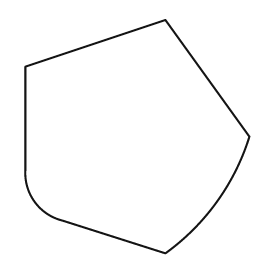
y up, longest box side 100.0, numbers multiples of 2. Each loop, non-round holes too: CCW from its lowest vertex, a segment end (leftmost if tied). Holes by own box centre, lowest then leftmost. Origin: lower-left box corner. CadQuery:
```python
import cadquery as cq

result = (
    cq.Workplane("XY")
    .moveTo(60.0, 0.0)
    .threePointArc((82.0, 22.0), (96.0, 50.0))
    .lineTo(60.0, 100.0)
    .lineTo(0.0, 80.0)
    .lineTo(0.0, 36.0)
    .threePointArc((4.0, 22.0), (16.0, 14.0))
    .close()
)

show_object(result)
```